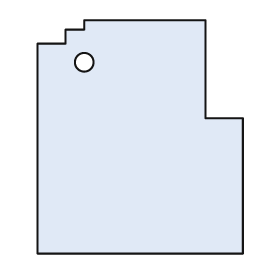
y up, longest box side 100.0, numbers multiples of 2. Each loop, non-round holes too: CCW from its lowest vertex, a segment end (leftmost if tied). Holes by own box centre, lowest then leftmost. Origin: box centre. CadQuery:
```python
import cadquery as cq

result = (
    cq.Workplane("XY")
    .moveTo(-44.0, -50.0)
    .lineTo(44.0, -50.0)
    .lineTo(44.0, 8.0)
    .lineTo(28.0, 8.0)
    .lineTo(28.0, 50.0)
    .lineTo(-24.0, 50.0)
    .lineTo(-24.0, 46.0)
    .lineTo(-32.0, 46.0)
    .lineTo(-32.0, 40.0)
    .lineTo(-44.0, 40.0)
    .close()
    .moveTo(-24.0, 32.0)
    .circle(4.0)
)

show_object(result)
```